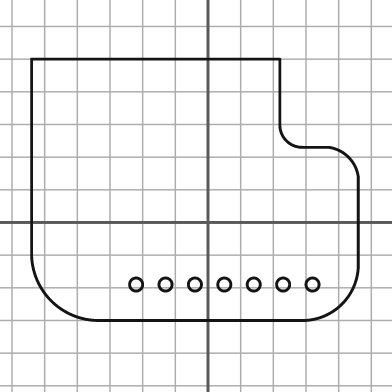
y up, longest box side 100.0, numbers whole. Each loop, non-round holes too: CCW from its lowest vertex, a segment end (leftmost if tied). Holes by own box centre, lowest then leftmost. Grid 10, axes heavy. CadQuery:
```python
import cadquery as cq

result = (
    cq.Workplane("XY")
    .moveTo(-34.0, -30.0)
    .lineTo(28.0, -30.0)
    .threePointArc((41.0, -25.0), (46.0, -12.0))
    .lineTo(46.0, 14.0)
    .threePointArc((43.0, 20.0), (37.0, 23.0))
    .lineTo(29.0, 23.0)
    .threePointArc((24.0, 25.0), (22.0, 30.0))
    .lineTo(22.0, 50.0)
    .lineTo(-54.0, 50.0)
    .lineTo(-54.0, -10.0)
    .threePointArc((-48.0, -24.0), (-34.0, -30.0))
    .close()
    .moveTo(-22.0, -19.0)
    .circle(2.0)
    .moveTo(-13.0, -19.0)
    .circle(2.0)
    .moveTo(-4.0, -19.0)
    .circle(2.0)
    .moveTo(5.0, -19.0)
    .circle(2.0)
    .moveTo(14.0, -19.0)
    .circle(2.0)
    .moveTo(23.0, -19.0)
    .circle(2.0)
    .moveTo(32.0, -19.0)
    .circle(2.0)
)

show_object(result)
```